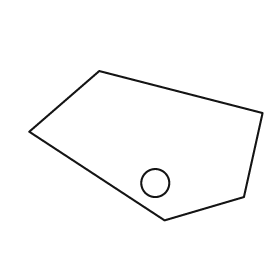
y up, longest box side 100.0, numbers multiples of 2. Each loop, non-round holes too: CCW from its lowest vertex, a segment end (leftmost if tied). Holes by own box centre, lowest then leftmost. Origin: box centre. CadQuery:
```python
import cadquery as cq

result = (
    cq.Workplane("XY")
    .moveTo(8.0, -32.0)
    .lineTo(42.0, -22.0)
    .lineTo(50.0, 14.0)
    .lineTo(-20.0, 32.0)
    .lineTo(-50.0, 6.0)
    .close()
    .moveTo(4.0, -16.0)
    .circle(6.0)
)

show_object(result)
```